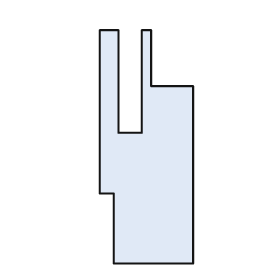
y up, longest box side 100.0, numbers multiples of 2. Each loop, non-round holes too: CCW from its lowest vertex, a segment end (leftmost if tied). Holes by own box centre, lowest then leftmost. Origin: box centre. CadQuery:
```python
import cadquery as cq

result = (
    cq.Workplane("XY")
    .moveTo(-14.0, -50.0)
    .lineTo(20.0, -50.0)
    .lineTo(20.0, 26.0)
    .lineTo(2.0, 26.0)
    .lineTo(2.0, 50.0)
    .lineTo(-2.0, 50.0)
    .lineTo(-2.0, 6.0)
    .lineTo(-12.0, 6.0)
    .lineTo(-12.0, 50.0)
    .lineTo(-20.0, 50.0)
    .lineTo(-20.0, -20.0)
    .lineTo(-14.0, -20.0)
    .close()
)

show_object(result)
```